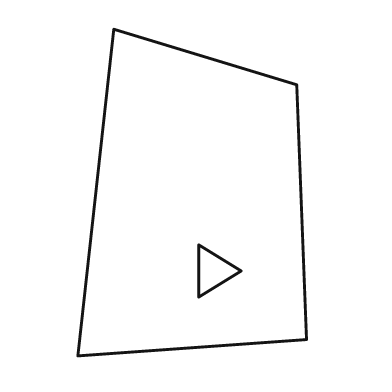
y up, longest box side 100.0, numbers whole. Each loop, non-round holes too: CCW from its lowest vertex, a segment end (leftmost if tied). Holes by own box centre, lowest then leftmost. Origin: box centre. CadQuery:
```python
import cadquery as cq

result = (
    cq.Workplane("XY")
    .moveTo(-35.0, -50.0)
    .lineTo(35.0, -45.0)
    .lineTo(32.0, 33.0)
    .lineTo(-24.0, 50.0)
    .close()
    .moveTo(2.0, -32.0)
    .lineTo(15.0, -24.0)
    .lineTo(2.0, -16.0)
    .close()
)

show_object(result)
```